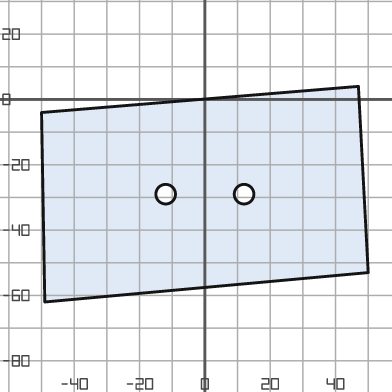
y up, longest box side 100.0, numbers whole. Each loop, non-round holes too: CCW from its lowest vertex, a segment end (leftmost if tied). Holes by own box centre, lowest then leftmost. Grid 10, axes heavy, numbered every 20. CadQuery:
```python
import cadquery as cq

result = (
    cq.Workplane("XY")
    .moveTo(-49.0, -62.0)
    .lineTo(50.0, -53.0)
    .lineTo(47.0, 4.0)
    .lineTo(-50.0, -4.0)
    .close()
    .moveTo(-12.0, -29.0)
    .circle(3.0)
    .moveTo(12.0, -29.0)
    .circle(3.0)
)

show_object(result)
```